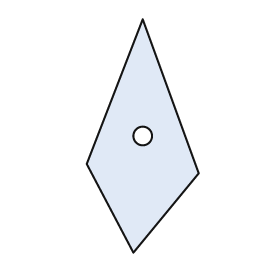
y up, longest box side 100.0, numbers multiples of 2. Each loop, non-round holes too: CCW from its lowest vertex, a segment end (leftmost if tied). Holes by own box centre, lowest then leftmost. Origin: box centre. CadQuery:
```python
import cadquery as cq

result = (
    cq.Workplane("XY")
    .moveTo(-4.0, -50.0)
    .lineTo(24.0, -16.0)
    .lineTo(0.0, 50.0)
    .lineTo(-24.0, -12.0)
    .close()
    .moveTo(0.0, 0.0)
    .circle(4.0)
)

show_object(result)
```